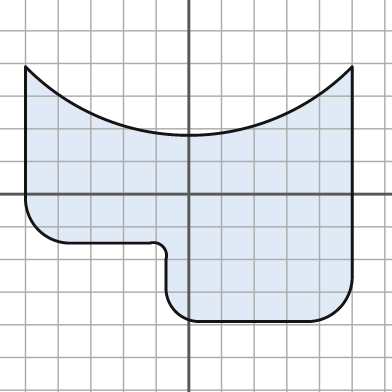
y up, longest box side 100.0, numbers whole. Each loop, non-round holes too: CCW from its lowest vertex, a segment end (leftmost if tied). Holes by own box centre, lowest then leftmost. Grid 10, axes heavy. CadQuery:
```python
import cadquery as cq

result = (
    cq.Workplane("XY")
    .moveTo(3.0, -39.0)
    .lineTo(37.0, -39.0)
    .threePointArc((46.0, -35.0), (50.0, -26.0))
    .lineTo(50.0, 39.0)
    .threePointArc((0.0, 18.0), (-50.0, 39.0))
    .lineTo(-50.0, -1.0)
    .threePointArc((-46.0, -11.0), (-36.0, -15.0))
    .lineTo(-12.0, -15.0)
    .threePointArc((-8.0, -16.0), (-7.0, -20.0))
    .lineTo(-7.0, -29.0)
    .threePointArc((-4.0, -36.0), (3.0, -39.0))
    .close()
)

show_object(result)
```